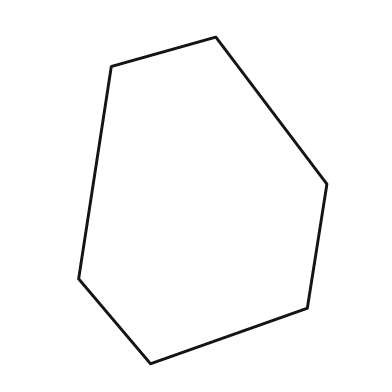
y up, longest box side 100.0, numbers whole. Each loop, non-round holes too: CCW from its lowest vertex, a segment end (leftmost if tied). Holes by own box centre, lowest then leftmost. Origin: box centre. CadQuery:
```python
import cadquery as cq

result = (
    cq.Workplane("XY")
    .moveTo(-16.0, -50.0)
    .lineTo(32.0, -33.0)
    .lineTo(38.0, 5.0)
    .lineTo(4.0, 50.0)
    .lineTo(-28.0, 41.0)
    .lineTo(-38.0, -24.0)
    .close()
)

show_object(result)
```